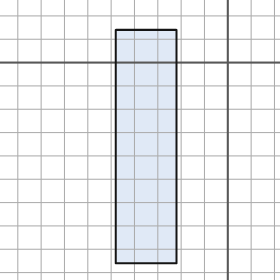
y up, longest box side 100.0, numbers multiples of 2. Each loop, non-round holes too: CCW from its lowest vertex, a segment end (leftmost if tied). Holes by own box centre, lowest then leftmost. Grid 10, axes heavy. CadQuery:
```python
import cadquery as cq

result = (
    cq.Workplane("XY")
    .moveTo(-48.0, -86.0)
    .lineTo(-22.0, -86.0)
    .lineTo(-22.0, 14.0)
    .lineTo(-48.0, 14.0)
    .close()
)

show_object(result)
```